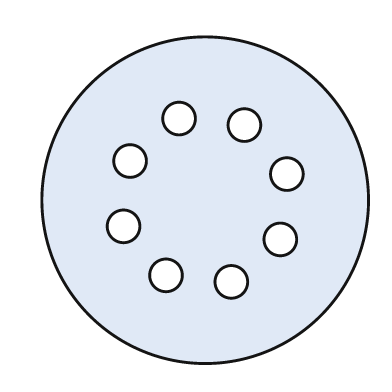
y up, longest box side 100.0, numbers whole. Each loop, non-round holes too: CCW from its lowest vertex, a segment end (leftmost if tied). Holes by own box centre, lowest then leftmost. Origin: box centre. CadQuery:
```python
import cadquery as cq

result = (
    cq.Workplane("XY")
    .moveTo(0.0, 0.0)
    .circle(50.0)
    .moveTo(8.0, -25.0)
    .circle(5.0)
    .moveTo(-12.0, -23.0)
    .circle(5.0)
    .moveTo(23.0, -12.0)
    .circle(5.0)
    .moveTo(-25.0, -8.0)
    .circle(5.0)
    .moveTo(25.0, 8.0)
    .circle(5.0)
    .moveTo(-23.0, 12.0)
    .circle(5.0)
    .moveTo(12.0, 23.0)
    .circle(5.0)
    .moveTo(-8.0, 25.0)
    .circle(5.0)
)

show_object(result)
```